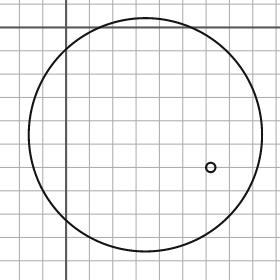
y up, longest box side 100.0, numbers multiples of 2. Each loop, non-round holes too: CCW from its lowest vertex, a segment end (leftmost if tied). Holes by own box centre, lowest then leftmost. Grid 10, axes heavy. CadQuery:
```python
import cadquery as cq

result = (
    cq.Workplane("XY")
    .moveTo(34.0, -46.0)
    .circle(50.0)
    .moveTo(62.0, -60.0)
    .circle(2.0)
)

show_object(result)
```